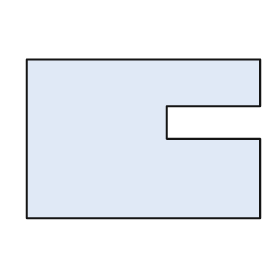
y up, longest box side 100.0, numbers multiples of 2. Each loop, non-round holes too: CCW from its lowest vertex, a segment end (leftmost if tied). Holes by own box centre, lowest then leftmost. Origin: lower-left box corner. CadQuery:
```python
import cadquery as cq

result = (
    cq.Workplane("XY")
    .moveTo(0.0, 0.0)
    .lineTo(100.0, 0.0)
    .lineTo(100.0, 34.0)
    .lineTo(60.0, 34.0)
    .lineTo(60.0, 48.0)
    .lineTo(100.0, 48.0)
    .lineTo(100.0, 68.0)
    .lineTo(0.0, 68.0)
    .close()
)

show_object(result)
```